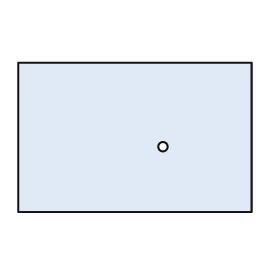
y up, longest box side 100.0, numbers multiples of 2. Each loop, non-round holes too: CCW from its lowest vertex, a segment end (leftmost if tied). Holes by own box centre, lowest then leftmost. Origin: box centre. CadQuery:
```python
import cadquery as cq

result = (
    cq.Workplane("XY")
    .moveTo(-50.0, -32.0)
    .lineTo(50.0, -32.0)
    .lineTo(50.0, 32.0)
    .lineTo(-50.0, 32.0)
    .close()
    .moveTo(12.0, -4.0)
    .circle(2.0)
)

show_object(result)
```